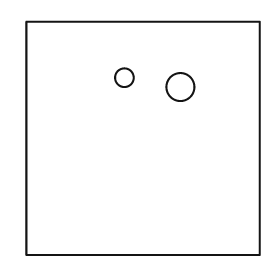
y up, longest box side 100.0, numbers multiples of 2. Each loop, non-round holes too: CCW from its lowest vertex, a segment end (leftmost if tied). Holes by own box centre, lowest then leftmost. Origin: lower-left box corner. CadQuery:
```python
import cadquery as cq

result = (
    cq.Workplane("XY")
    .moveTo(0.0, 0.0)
    .lineTo(100.0, 0.0)
    .lineTo(100.0, 100.0)
    .lineTo(0.0, 100.0)
    .close()
    .moveTo(66.0, 72.0)
    .circle(6.0)
    .moveTo(42.0, 76.0)
    .circle(4.0)
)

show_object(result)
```